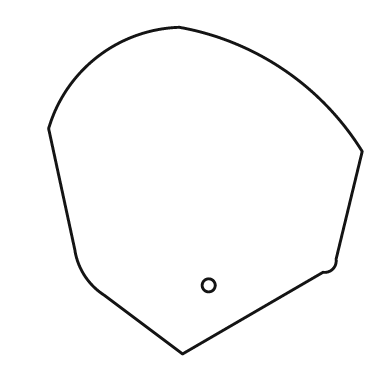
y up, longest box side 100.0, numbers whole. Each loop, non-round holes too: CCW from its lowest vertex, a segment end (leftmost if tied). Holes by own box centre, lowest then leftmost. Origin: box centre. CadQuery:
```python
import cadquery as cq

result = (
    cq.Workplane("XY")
    .moveTo(-7.0, -50.0)
    .lineTo(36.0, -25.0)
    .threePointArc((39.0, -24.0), (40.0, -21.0))
    .lineTo(48.0, 12.0)
    .threePointArc((24.0, 37.0), (-8.0, 50.0))
    .threePointArc((-33.0, 41.0), (-48.0, 19.0))
    .lineTo(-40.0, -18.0)
    .threePointArc((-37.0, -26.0), (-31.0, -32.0))
    .close()
    .moveTo(1.0, -29.0)
    .circle(2.0)
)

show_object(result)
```